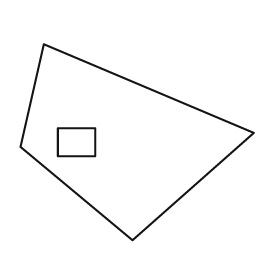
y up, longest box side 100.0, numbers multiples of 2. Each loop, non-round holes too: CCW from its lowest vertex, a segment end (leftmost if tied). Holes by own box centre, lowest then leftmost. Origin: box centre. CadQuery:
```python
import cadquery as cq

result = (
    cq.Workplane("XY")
    .moveTo(-2.0, -42.0)
    .lineTo(50.0, 4.0)
    .lineTo(-40.0, 42.0)
    .lineTo(-50.0, -2.0)
    .close()
    .moveTo(-34.0, -6.0)
    .lineTo(-18.0, -6.0)
    .lineTo(-18.0, 6.0)
    .lineTo(-34.0, 6.0)
    .close()
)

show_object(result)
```